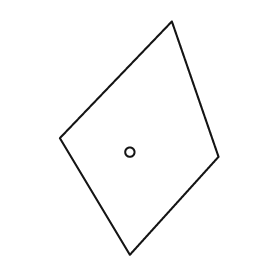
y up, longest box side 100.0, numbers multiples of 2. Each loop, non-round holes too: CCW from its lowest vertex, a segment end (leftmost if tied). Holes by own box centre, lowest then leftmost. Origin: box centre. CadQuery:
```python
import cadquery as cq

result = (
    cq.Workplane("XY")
    .moveTo(-4.0, -50.0)
    .lineTo(34.0, -8.0)
    .lineTo(14.0, 50.0)
    .lineTo(-34.0, 0.0)
    .close()
    .moveTo(-4.0, -6.0)
    .circle(2.0)
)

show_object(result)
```